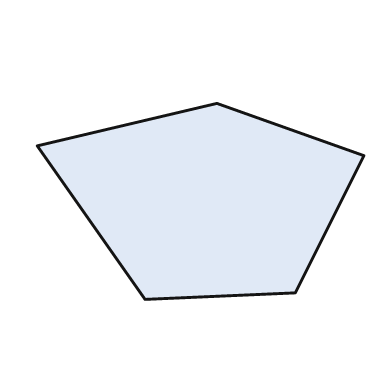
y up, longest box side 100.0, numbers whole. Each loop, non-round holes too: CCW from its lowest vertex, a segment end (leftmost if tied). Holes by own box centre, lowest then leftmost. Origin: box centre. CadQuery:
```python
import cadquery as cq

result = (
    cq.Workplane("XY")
    .moveTo(-17.0, -30.0)
    .lineTo(29.0, -28.0)
    .lineTo(50.0, 14.0)
    .lineTo(5.0, 30.0)
    .lineTo(-50.0, 17.0)
    .close()
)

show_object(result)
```